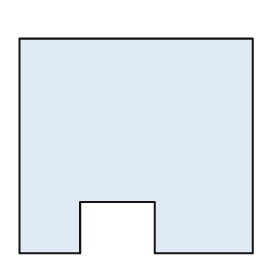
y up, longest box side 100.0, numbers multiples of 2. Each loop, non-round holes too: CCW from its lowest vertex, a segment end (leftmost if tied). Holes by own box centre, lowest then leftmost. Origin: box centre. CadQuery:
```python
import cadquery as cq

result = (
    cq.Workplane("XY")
    .moveTo(-50.0, -46.0)
    .lineTo(-24.0, -46.0)
    .lineTo(-24.0, -24.0)
    .lineTo(8.0, -24.0)
    .lineTo(8.0, -46.0)
    .lineTo(50.0, -46.0)
    .lineTo(50.0, 46.0)
    .lineTo(-50.0, 46.0)
    .close()
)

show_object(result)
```